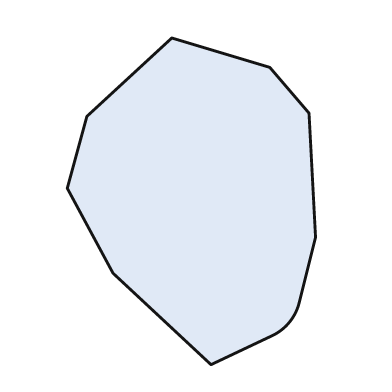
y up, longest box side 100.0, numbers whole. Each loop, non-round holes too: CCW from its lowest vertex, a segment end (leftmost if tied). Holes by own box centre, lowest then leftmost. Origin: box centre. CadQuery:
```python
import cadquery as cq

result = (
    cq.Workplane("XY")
    .moveTo(6.0, -50.0)
    .lineTo(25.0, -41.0)
    .threePointArc((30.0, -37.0), (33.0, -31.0))
    .lineTo(38.0, -11.0)
    .lineTo(36.0, 27.0)
    .lineTo(24.0, 41.0)
    .lineTo(-6.0, 50.0)
    .lineTo(-32.0, 26.0)
    .lineTo(-38.0, 4.0)
    .lineTo(-24.0, -22.0)
    .close()
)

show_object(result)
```